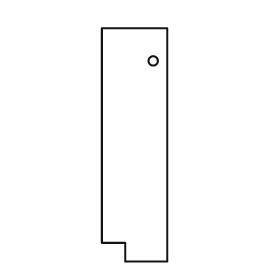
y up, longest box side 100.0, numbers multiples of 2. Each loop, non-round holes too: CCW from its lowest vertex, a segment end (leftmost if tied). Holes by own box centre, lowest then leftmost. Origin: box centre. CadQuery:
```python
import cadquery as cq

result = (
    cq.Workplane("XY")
    .moveTo(-4.0, -50.0)
    .lineTo(14.0, -50.0)
    .lineTo(14.0, 50.0)
    .lineTo(-14.0, 50.0)
    .lineTo(-14.0, -42.0)
    .lineTo(-4.0, -42.0)
    .close()
    .moveTo(8.0, 36.0)
    .circle(2.0)
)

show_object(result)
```